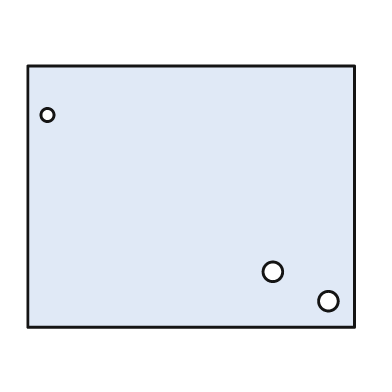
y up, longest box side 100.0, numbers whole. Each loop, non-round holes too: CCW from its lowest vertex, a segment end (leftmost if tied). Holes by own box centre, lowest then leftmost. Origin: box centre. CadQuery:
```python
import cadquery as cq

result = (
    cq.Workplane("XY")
    .moveTo(-50.0, -40.0)
    .lineTo(50.0, -40.0)
    .lineTo(50.0, 40.0)
    .lineTo(-50.0, 40.0)
    .close()
    .moveTo(42.0, -32.0)
    .circle(3.0)
    .moveTo(25.0, -23.0)
    .circle(3.0)
    .moveTo(-44.0, 25.0)
    .circle(2.0)
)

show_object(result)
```